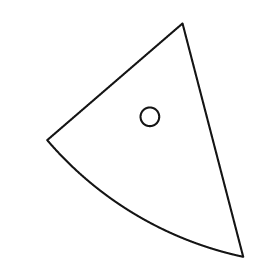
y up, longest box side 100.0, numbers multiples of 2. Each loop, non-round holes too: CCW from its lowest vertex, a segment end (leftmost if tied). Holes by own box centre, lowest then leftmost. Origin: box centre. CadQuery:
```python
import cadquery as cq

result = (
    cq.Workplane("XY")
    .moveTo(42.0, -50.0)
    .lineTo(16.0, 50.0)
    .lineTo(-42.0, 0.0)
    .threePointArc((-4.0, -32.0), (42.0, -50.0))
    .close()
    .moveTo(2.0, 10.0)
    .circle(4.0)
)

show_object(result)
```